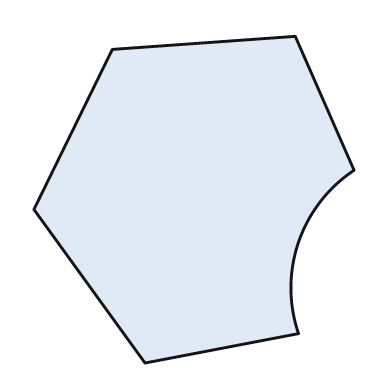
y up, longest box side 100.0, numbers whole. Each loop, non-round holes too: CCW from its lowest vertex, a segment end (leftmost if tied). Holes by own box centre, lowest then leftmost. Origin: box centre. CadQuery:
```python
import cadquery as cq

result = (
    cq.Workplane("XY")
    .moveTo(-15.0, -50.0)
    .lineTo(32.0, -41.0)
    .threePointArc((32.0, -13.0), (49.0, 9.0))
    .lineTo(31.0, 50.0)
    .lineTo(-25.0, 46.0)
    .lineTo(-49.0, -3.0)
    .close()
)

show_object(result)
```